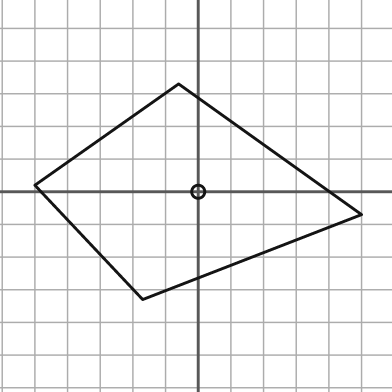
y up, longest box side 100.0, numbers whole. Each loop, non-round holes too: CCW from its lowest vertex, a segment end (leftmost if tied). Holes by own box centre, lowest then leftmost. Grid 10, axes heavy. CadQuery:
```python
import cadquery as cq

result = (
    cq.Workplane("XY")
    .moveTo(-17.0, -33.0)
    .lineTo(50.0, -7.0)
    .lineTo(-6.0, 33.0)
    .lineTo(-50.0, 2.0)
    .close()
    .moveTo(0.0, 0.0)
    .circle(2.0)
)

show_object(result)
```